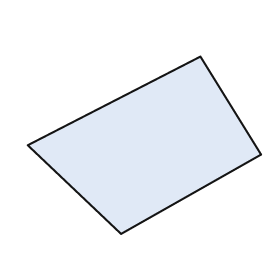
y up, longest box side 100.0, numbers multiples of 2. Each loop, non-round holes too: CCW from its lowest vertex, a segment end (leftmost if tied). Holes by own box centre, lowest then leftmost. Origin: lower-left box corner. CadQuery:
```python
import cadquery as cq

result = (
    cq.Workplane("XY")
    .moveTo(40.0, 0.0)
    .lineTo(100.0, 34.0)
    .lineTo(74.0, 76.0)
    .lineTo(0.0, 38.0)
    .close()
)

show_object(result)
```